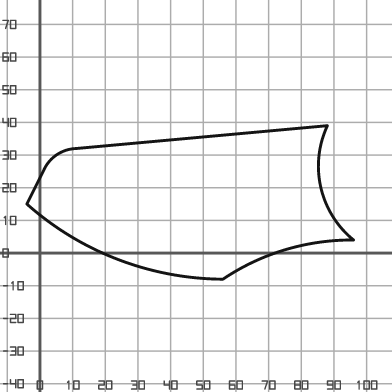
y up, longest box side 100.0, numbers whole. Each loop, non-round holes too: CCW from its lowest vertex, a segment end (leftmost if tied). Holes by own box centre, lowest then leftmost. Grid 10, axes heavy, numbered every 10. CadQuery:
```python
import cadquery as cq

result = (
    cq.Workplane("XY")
    .moveTo(56.0, -8.0)
    .threePointArc((75.0, 1.0), (96.0, 4.0))
    .threePointArc((86.0, 20.0), (88.0, 39.0))
    .lineTo(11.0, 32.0)
    .threePointArc((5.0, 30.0), (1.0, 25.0))
    .lineTo(-4.0, 15.0)
    .threePointArc((24.0, -2.0), (56.0, -8.0))
    .close()
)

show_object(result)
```